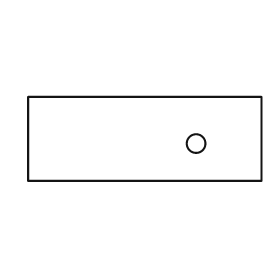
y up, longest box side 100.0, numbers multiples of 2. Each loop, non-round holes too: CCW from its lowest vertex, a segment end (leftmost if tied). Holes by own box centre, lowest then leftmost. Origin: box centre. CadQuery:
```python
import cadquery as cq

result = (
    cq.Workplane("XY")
    .moveTo(-50.0, -18.0)
    .lineTo(50.0, -18.0)
    .lineTo(50.0, 18.0)
    .lineTo(-50.0, 18.0)
    .close()
    .moveTo(22.0, -2.0)
    .circle(4.0)
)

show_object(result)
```